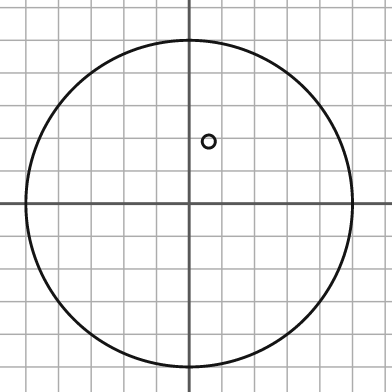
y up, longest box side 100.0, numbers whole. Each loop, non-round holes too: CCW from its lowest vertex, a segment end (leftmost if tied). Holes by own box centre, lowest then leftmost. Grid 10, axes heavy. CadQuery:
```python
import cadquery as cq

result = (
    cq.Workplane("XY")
    .moveTo(0.0, 0.0)
    .circle(50.0)
    .moveTo(6.0, 19.0)
    .circle(2.0)
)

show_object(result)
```